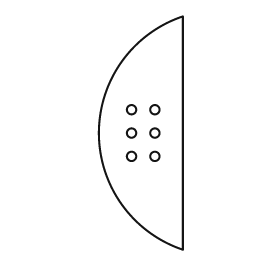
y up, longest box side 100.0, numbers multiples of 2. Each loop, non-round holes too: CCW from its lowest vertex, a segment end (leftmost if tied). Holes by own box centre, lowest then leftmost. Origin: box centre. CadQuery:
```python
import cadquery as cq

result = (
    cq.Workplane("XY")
    .moveTo(18.0, -50.0)
    .lineTo(18.0, 50.0)
    .threePointArc((-18.0, 0.0), (18.0, -50.0))
    .close()
    .moveTo(-4.0, -10.0)
    .circle(2.0)
    .moveTo(6.0, -10.0)
    .circle(2.0)
    .moveTo(-4.0, 0.0)
    .circle(2.0)
    .moveTo(6.0, 0.0)
    .circle(2.0)
    .moveTo(-4.0, 10.0)
    .circle(2.0)
    .moveTo(6.0, 10.0)
    .circle(2.0)
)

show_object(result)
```